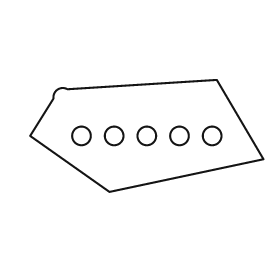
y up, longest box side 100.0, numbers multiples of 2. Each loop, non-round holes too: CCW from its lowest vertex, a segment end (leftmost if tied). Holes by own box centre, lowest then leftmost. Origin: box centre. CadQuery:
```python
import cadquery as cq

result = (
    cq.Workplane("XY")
    .moveTo(-16.0, -24.0)
    .lineTo(50.0, -10.0)
    .lineTo(30.0, 24.0)
    .lineTo(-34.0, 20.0)
    .threePointArc((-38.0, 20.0), (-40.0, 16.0))
    .lineTo(-50.0, 0.0)
    .close()
    .moveTo(-28.0, 0.0)
    .circle(4.0)
    .moveTo(-14.0, 0.0)
    .circle(4.0)
    .moveTo(0.0, 0.0)
    .circle(4.0)
    .moveTo(14.0, 0.0)
    .circle(4.0)
    .moveTo(28.0, 0.0)
    .circle(4.0)
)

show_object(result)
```